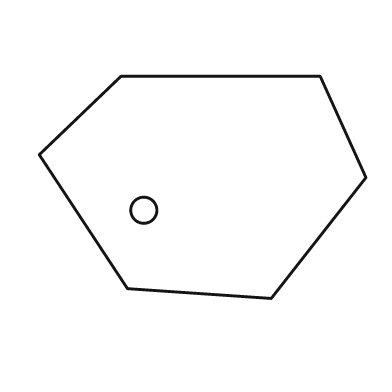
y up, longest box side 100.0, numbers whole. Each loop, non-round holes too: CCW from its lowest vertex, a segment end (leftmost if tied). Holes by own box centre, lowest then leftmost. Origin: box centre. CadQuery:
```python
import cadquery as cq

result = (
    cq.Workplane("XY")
    .moveTo(21.0, -34.0)
    .lineTo(50.0, 3.0)
    .lineTo(36.0, 34.0)
    .lineTo(-25.0, 34.0)
    .lineTo(-50.0, 10.0)
    .lineTo(-23.0, -31.0)
    .close()
    .moveTo(-18.0, -7.0)
    .circle(4.0)
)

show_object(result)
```